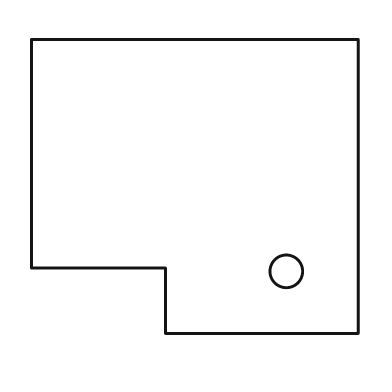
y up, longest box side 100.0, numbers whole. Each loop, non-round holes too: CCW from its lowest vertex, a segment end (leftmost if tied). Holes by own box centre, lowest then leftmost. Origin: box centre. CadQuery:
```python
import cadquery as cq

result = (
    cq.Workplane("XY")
    .moveTo(-9.0, -45.0)
    .lineTo(50.0, -45.0)
    .lineTo(50.0, 45.0)
    .lineTo(-50.0, 45.0)
    .lineTo(-50.0, -25.0)
    .lineTo(-9.0, -25.0)
    .close()
    .moveTo(28.0, -26.0)
    .circle(5.0)
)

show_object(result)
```